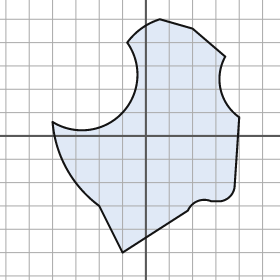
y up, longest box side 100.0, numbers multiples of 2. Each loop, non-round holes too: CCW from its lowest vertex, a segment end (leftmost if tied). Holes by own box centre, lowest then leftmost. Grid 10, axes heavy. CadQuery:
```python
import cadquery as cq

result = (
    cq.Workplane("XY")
    .moveTo(-10.0, -50.0)
    .lineTo(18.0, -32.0)
    .threePointArc((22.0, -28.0), (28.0, -28.0))
    .lineTo(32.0, -28.0)
    .threePointArc((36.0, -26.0), (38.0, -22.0))
    .lineTo(40.0, 8.0)
    .threePointArc((32.0, 20.0), (34.0, 34.0))
    .lineTo(20.0, 46.0)
    .lineTo(6.0, 50.0)
    .threePointArc((-2.0, 46.0), (-8.0, 40.0))
    .threePointArc((-10.0, 10.0), (-40.0, 6.0))
    .threePointArc((-34.0, -14.0), (-20.0, -30.0))
    .close()
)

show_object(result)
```